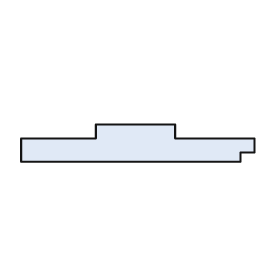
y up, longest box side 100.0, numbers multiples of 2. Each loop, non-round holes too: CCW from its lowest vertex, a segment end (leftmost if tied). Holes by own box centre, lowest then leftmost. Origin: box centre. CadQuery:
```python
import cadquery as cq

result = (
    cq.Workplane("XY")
    .moveTo(-50.0, -8.0)
    .lineTo(44.0, -8.0)
    .lineTo(44.0, -4.0)
    .lineTo(50.0, -4.0)
    .lineTo(50.0, 2.0)
    .lineTo(16.0, 2.0)
    .lineTo(16.0, 8.0)
    .lineTo(-18.0, 8.0)
    .lineTo(-18.0, 2.0)
    .lineTo(-50.0, 2.0)
    .close()
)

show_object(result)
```